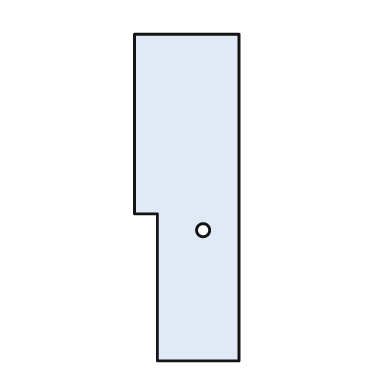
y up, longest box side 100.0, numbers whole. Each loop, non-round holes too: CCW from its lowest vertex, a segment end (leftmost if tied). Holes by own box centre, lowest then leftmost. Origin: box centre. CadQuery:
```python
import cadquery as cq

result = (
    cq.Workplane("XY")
    .moveTo(-9.0, -50.0)
    .lineTo(16.0, -50.0)
    .lineTo(16.0, 50.0)
    .lineTo(-16.0, 50.0)
    .lineTo(-16.0, -5.0)
    .lineTo(-9.0, -5.0)
    .close()
    .moveTo(5.0, -10.0)
    .circle(2.0)
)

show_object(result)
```